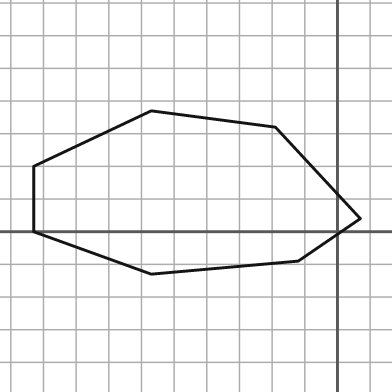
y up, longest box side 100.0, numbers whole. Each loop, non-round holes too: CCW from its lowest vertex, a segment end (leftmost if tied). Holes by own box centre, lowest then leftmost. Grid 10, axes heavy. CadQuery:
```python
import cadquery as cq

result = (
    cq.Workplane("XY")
    .moveTo(-57.0, -13.0)
    .lineTo(-12.0, -9.0)
    .lineTo(7.0, 4.0)
    .lineTo(-19.0, 32.0)
    .lineTo(-57.0, 37.0)
    .lineTo(-93.0, 20.0)
    .lineTo(-93.0, 0.0)
    .close()
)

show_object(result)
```